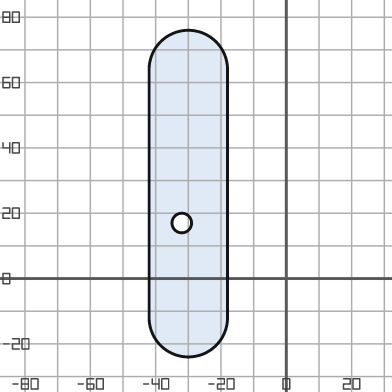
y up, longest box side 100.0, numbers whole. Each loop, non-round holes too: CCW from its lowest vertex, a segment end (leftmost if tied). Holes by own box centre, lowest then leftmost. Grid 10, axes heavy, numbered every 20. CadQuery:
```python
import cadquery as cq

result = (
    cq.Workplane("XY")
    .moveTo(-42.0, -12.0)
    .threePointArc((-30.0, -24.0), (-18.0, -12.0))
    .lineTo(-18.0, 64.0)
    .threePointArc((-30.0, 76.0), (-42.0, 64.0))
    .close()
    .moveTo(-32.0, 17.0)
    .circle(3.0)
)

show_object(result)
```